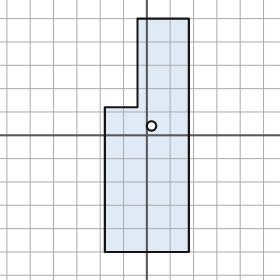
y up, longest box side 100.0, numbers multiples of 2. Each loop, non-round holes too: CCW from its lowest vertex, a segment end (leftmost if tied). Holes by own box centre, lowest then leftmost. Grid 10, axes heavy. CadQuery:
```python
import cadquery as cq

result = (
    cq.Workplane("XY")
    .moveTo(-18.0, -50.0)
    .lineTo(18.0, -50.0)
    .lineTo(18.0, 50.0)
    .lineTo(-4.0, 50.0)
    .lineTo(-4.0, 12.0)
    .lineTo(-18.0, 12.0)
    .close()
    .moveTo(2.0, 4.0)
    .circle(2.0)
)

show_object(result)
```